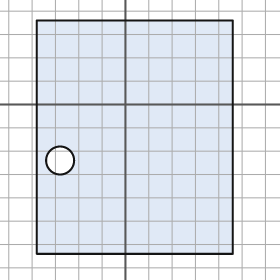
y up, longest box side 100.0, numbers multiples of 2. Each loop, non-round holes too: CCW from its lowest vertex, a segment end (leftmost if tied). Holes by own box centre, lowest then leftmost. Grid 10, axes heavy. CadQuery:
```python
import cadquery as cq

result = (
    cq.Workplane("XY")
    .moveTo(-38.0, -64.0)
    .lineTo(46.0, -64.0)
    .lineTo(46.0, 36.0)
    .lineTo(-38.0, 36.0)
    .close()
    .moveTo(-28.0, -24.0)
    .circle(6.0)
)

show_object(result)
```